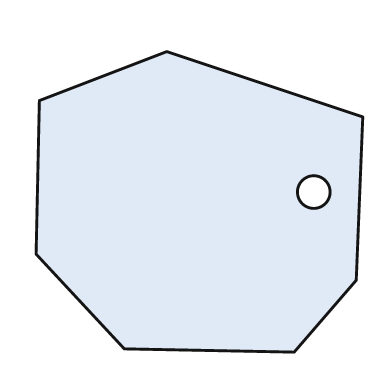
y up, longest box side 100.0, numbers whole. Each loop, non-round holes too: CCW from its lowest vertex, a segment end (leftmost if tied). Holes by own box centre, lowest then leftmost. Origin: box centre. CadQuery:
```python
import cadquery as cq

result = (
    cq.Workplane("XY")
    .moveTo(29.0, -46.0)
    .lineTo(48.0, -24.0)
    .lineTo(50.0, 26.0)
    .lineTo(-10.0, 46.0)
    .lineTo(-49.0, 31.0)
    .lineTo(-50.0, -16.0)
    .lineTo(-23.0, -45.0)
    .close()
    .moveTo(35.0, 3.0)
    .circle(5.0)
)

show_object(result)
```